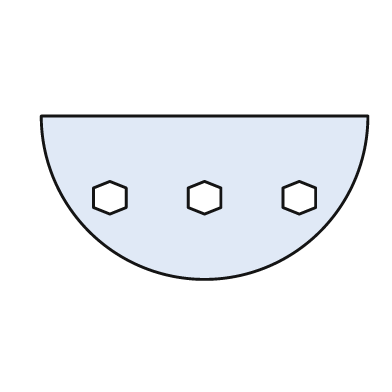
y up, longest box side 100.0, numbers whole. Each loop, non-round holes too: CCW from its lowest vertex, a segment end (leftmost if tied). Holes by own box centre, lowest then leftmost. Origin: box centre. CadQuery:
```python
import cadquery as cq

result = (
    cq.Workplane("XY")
    .moveTo(-50.0, 25.0)
    .threePointArc((0.0, -25.0), (50.0, 25.0))
    .close()
    .moveTo(-29.0, -5.0)
    .lineTo(-24.0, -3.0)
    .lineTo(-24.0, 3.0)
    .lineTo(-29.0, 5.0)
    .lineTo(-34.0, 3.0)
    .lineTo(-34.0, -3.0)
    .close()
    .moveTo(0.0, -5.0)
    .lineTo(5.0, -3.0)
    .lineTo(5.0, 3.0)
    .lineTo(0.0, 5.0)
    .lineTo(-5.0, 3.0)
    .lineTo(-5.0, -3.0)
    .close()
    .moveTo(29.0, -5.0)
    .lineTo(34.0, -3.0)
    .lineTo(34.0, 3.0)
    .lineTo(29.0, 5.0)
    .lineTo(24.0, 3.0)
    .lineTo(24.0, -3.0)
    .close()
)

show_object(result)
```